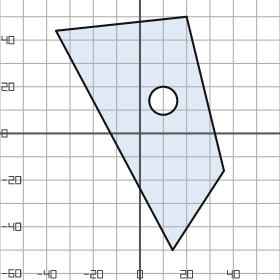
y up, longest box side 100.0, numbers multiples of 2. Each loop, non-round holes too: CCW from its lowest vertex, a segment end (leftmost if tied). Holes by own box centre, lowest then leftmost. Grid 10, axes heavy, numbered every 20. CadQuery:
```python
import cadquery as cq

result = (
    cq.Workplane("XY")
    .moveTo(14.0, -50.0)
    .lineTo(36.0, -16.0)
    .lineTo(20.0, 50.0)
    .lineTo(-36.0, 44.0)
    .close()
    .moveTo(10.0, 14.0)
    .circle(6.0)
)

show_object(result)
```